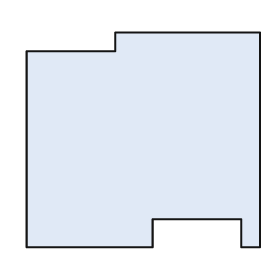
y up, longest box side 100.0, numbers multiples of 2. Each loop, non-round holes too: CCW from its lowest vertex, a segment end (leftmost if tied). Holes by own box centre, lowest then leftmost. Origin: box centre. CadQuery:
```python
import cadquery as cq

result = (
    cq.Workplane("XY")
    .moveTo(-50.0, -46.0)
    .lineTo(4.0, -46.0)
    .lineTo(4.0, -34.0)
    .lineTo(42.0, -34.0)
    .lineTo(42.0, -46.0)
    .lineTo(50.0, -46.0)
    .lineTo(50.0, 46.0)
    .lineTo(-12.0, 46.0)
    .lineTo(-12.0, 38.0)
    .lineTo(-50.0, 38.0)
    .close()
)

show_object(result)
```